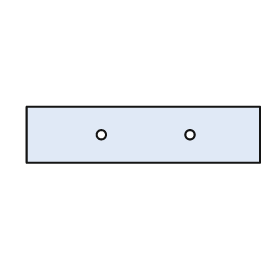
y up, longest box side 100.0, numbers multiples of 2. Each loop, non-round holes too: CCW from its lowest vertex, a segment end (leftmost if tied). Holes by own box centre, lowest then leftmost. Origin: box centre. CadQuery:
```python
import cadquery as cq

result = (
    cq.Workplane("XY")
    .moveTo(-50.0, -12.0)
    .lineTo(50.0, -12.0)
    .lineTo(50.0, 12.0)
    .lineTo(-50.0, 12.0)
    .close()
    .moveTo(-18.0, 0.0)
    .circle(2.0)
    .moveTo(20.0, 0.0)
    .circle(2.0)
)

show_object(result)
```